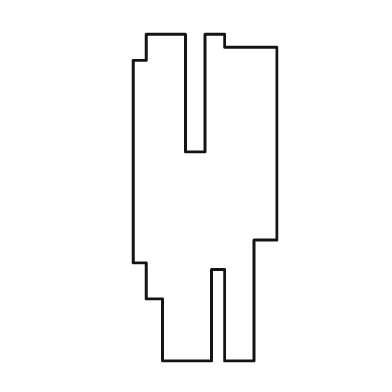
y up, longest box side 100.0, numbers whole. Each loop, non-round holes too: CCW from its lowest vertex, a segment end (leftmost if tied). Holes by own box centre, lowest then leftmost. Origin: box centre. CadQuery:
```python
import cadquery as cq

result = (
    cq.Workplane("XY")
    .moveTo(-13.0, -50.0)
    .lineTo(2.0, -50.0)
    .lineTo(2.0, -22.0)
    .lineTo(6.0, -22.0)
    .lineTo(6.0, -50.0)
    .lineTo(15.0, -50.0)
    .lineTo(15.0, -13.0)
    .lineTo(22.0, -13.0)
    .lineTo(22.0, 46.0)
    .lineTo(6.0, 46.0)
    .lineTo(6.0, 50.0)
    .lineTo(0.0, 50.0)
    .lineTo(0.0, 14.0)
    .lineTo(-6.0, 14.0)
    .lineTo(-6.0, 50.0)
    .lineTo(-18.0, 50.0)
    .lineTo(-18.0, 42.0)
    .lineTo(-22.0, 42.0)
    .lineTo(-22.0, -20.0)
    .lineTo(-18.0, -20.0)
    .lineTo(-18.0, -31.0)
    .lineTo(-13.0, -31.0)
    .close()
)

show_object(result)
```